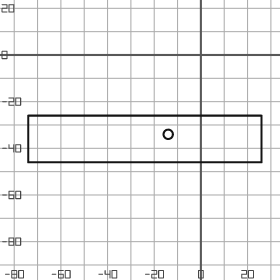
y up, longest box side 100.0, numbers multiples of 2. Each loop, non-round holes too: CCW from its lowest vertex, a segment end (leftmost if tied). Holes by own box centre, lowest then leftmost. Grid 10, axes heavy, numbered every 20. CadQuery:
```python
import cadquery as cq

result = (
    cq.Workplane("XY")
    .moveTo(-74.0, -46.0)
    .lineTo(26.0, -46.0)
    .lineTo(26.0, -26.0)
    .lineTo(-74.0, -26.0)
    .close()
    .moveTo(-14.0, -34.0)
    .circle(2.0)
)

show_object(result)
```